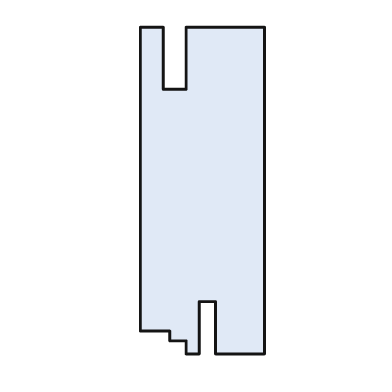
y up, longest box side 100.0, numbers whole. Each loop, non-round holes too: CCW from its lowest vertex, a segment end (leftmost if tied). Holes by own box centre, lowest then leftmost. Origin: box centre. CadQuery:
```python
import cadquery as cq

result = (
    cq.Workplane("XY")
    .moveTo(-5.0, -50.0)
    .lineTo(-1.0, -50.0)
    .lineTo(-1.0, -34.0)
    .lineTo(4.0, -34.0)
    .lineTo(4.0, -50.0)
    .lineTo(19.0, -50.0)
    .lineTo(19.0, 50.0)
    .lineTo(-5.0, 50.0)
    .lineTo(-5.0, 31.0)
    .lineTo(-12.0, 31.0)
    .lineTo(-12.0, 50.0)
    .lineTo(-19.0, 50.0)
    .lineTo(-19.0, -43.0)
    .lineTo(-10.0, -43.0)
    .lineTo(-10.0, -46.0)
    .lineTo(-5.0, -46.0)
    .close()
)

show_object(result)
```